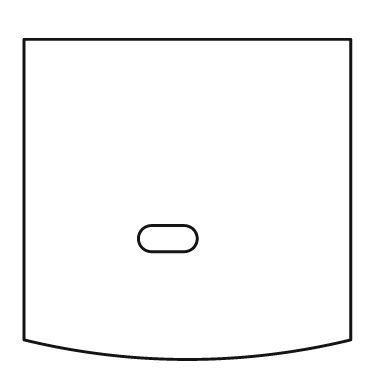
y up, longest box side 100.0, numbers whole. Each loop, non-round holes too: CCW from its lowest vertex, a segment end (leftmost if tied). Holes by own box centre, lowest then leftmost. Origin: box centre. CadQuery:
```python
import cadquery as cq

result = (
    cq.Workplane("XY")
    .moveTo(-50.0, -43.0)
    .threePointArc((0.0, -49.0), (50.0, -43.0))
    .lineTo(50.0, 49.0)
    .lineTo(-50.0, 49.0)
    .close()
    .moveTo(-11.0, -16.0)
    .lineTo(-1.0, -16.0)
    .threePointArc((3.0, -12.0), (-1.0, -8.0))
    .lineTo(-11.0, -8.0)
    .threePointArc((-15.0, -12.0), (-11.0, -16.0))
    .close()
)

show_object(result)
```